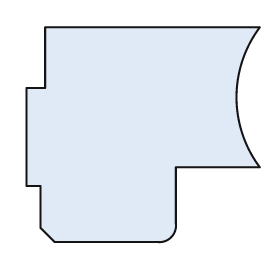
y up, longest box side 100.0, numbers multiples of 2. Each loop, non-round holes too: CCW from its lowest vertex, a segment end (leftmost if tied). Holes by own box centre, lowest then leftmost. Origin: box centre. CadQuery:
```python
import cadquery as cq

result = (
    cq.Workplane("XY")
    .moveTo(-38.0, -46.0)
    .lineTo(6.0, -46.0)
    .threePointArc((12.0, -44.0), (14.0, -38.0))
    .lineTo(14.0, -14.0)
    .lineTo(50.0, -14.0)
    .threePointArc((40.0, 16.0), (50.0, 46.0))
    .lineTo(-42.0, 46.0)
    .lineTo(-42.0, 20.0)
    .lineTo(-50.0, 20.0)
    .lineTo(-50.0, -22.0)
    .lineTo(-44.0, -22.0)
    .lineTo(-44.0, -40.0)
    .close()
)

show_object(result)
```